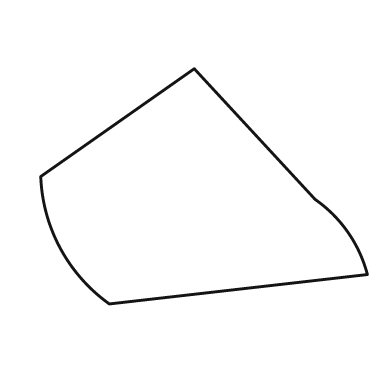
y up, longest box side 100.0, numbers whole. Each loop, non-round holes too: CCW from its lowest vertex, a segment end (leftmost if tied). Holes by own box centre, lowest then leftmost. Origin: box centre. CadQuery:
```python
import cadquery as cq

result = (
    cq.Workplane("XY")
    .moveTo(-29.0, -36.0)
    .lineTo(50.0, -27.0)
    .threePointArc((44.0, -14.0), (34.0, -4.0))
    .lineTo(-3.0, 36.0)
    .lineTo(-50.0, 3.0)
    .threePointArc((-44.0, -19.0), (-29.0, -36.0))
    .close()
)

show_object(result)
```